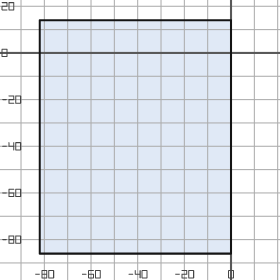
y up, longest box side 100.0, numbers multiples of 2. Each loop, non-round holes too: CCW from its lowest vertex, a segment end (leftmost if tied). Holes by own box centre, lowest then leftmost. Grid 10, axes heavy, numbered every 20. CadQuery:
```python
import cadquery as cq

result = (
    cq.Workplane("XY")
    .moveTo(-82.0, -86.0)
    .lineTo(0.0, -86.0)
    .lineTo(0.0, 14.0)
    .lineTo(-82.0, 14.0)
    .close()
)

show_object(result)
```